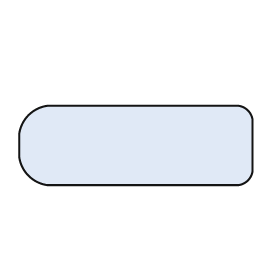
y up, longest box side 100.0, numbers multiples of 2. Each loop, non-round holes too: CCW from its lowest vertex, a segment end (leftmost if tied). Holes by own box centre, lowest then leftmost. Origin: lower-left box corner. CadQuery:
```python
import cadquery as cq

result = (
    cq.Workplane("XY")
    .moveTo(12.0, 0.0)
    .lineTo(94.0, 0.0)
    .threePointArc((98.0, 2.0), (100.0, 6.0))
    .lineTo(100.0, 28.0)
    .threePointArc((98.0, 32.0), (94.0, 34.0))
    .lineTo(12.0, 34.0)
    .threePointArc((4.0, 30.0), (0.0, 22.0))
    .lineTo(0.0, 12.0)
    .threePointArc((4.0, 4.0), (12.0, 0.0))
    .close()
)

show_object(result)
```